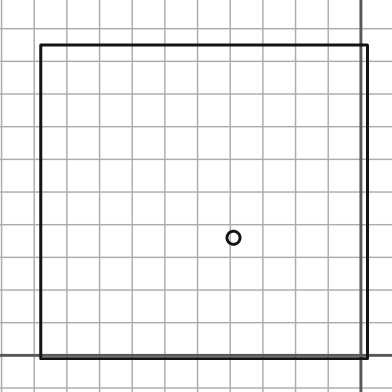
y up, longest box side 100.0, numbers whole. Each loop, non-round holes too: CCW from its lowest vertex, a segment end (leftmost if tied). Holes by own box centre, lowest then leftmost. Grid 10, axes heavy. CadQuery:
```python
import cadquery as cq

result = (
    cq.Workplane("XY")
    .moveTo(-98.0, -1.0)
    .lineTo(2.0, -1.0)
    .lineTo(2.0, 95.0)
    .lineTo(-98.0, 95.0)
    .close()
    .moveTo(-39.0, 36.0)
    .circle(2.0)
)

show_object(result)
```